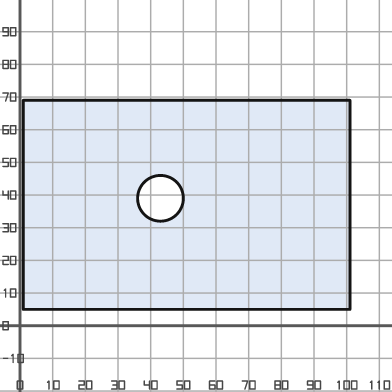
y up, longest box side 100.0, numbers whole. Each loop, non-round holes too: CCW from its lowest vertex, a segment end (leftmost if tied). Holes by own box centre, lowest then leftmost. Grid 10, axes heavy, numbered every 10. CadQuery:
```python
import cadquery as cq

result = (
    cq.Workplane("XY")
    .moveTo(1.0, 5.0)
    .lineTo(101.0, 5.0)
    .lineTo(101.0, 69.0)
    .lineTo(1.0, 69.0)
    .close()
    .moveTo(43.0, 39.0)
    .circle(7.0)
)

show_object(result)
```